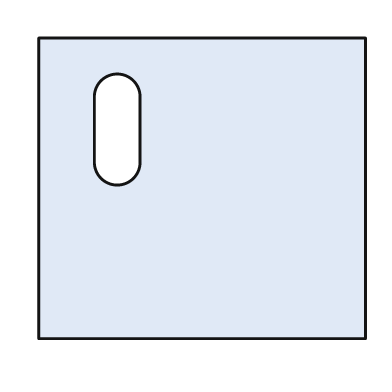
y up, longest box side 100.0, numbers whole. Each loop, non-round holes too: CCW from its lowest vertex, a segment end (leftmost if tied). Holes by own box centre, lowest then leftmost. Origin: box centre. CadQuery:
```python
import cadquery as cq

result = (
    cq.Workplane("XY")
    .moveTo(-50.0, -46.0)
    .lineTo(50.0, -46.0)
    .lineTo(50.0, 46.0)
    .lineTo(-50.0, 46.0)
    .close()
    .moveTo(-33.0, 8.0)
    .threePointArc((-26.0, 1.0), (-19.0, 8.0))
    .lineTo(-19.0, 28.0)
    .threePointArc((-26.0, 35.0), (-33.0, 28.0))
    .close()
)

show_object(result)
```